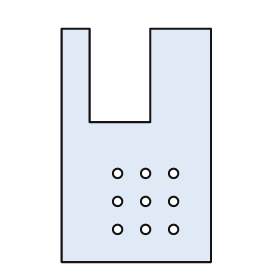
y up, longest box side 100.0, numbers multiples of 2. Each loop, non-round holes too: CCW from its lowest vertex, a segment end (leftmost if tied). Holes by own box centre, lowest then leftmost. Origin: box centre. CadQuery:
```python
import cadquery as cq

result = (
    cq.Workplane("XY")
    .moveTo(-32.0, -50.0)
    .lineTo(32.0, -50.0)
    .lineTo(32.0, 50.0)
    .lineTo(6.0, 50.0)
    .lineTo(6.0, 10.0)
    .lineTo(-20.0, 10.0)
    .lineTo(-20.0, 50.0)
    .lineTo(-32.0, 50.0)
    .close()
    .moveTo(-8.0, -36.0)
    .circle(2.0)
    .moveTo(4.0, -36.0)
    .circle(2.0)
    .moveTo(16.0, -36.0)
    .circle(2.0)
    .moveTo(-8.0, -24.0)
    .circle(2.0)
    .moveTo(4.0, -24.0)
    .circle(2.0)
    .moveTo(16.0, -24.0)
    .circle(2.0)
    .moveTo(-8.0, -12.0)
    .circle(2.0)
    .moveTo(4.0, -12.0)
    .circle(2.0)
    .moveTo(16.0, -12.0)
    .circle(2.0)
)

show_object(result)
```